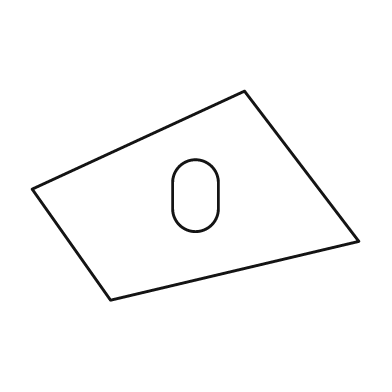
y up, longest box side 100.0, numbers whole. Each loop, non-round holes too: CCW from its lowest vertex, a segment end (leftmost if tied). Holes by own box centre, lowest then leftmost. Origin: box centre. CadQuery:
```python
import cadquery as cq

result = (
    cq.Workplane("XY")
    .moveTo(-26.0, -32.0)
    .lineTo(50.0, -14.0)
    .lineTo(15.0, 32.0)
    .lineTo(-50.0, 2.0)
    .close()
    .moveTo(-7.0, -4.0)
    .threePointArc((0.0, -11.0), (7.0, -4.0))
    .lineTo(7.0, 4.0)
    .threePointArc((0.0, 11.0), (-7.0, 4.0))
    .close()
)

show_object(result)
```